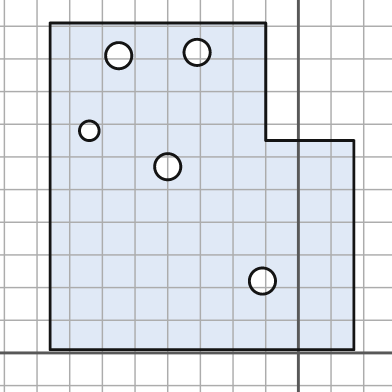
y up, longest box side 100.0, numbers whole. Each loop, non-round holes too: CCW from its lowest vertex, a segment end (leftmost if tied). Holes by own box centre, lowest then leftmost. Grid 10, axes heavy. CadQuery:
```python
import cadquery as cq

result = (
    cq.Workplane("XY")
    .moveTo(-76.0, 1.0)
    .lineTo(17.0, 1.0)
    .lineTo(17.0, 65.0)
    .lineTo(-10.0, 65.0)
    .lineTo(-10.0, 101.0)
    .lineTo(-76.0, 101.0)
    .close()
    .moveTo(-11.0, 22.0)
    .circle(4.0)
    .moveTo(-40.0, 57.0)
    .circle(4.0)
    .moveTo(-64.0, 68.0)
    .circle(3.0)
    .moveTo(-55.0, 91.0)
    .circle(4.0)
    .moveTo(-31.0, 92.0)
    .circle(4.0)
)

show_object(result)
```